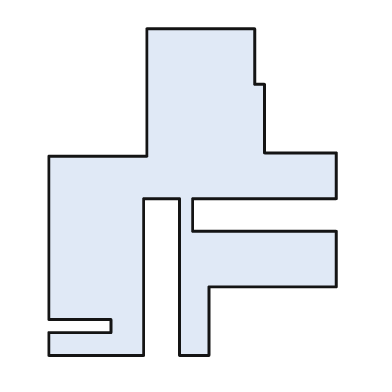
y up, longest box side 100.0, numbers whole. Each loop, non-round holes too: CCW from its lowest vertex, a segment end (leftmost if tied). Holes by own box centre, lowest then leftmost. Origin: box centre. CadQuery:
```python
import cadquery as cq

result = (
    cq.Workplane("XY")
    .moveTo(-44.0, -50.0)
    .lineTo(-15.0, -50.0)
    .lineTo(-15.0, -2.0)
    .lineTo(-4.0, -2.0)
    .lineTo(-4.0, -50.0)
    .lineTo(5.0, -50.0)
    .lineTo(5.0, -29.0)
    .lineTo(44.0, -29.0)
    .lineTo(44.0, -12.0)
    .lineTo(0.0, -12.0)
    .lineTo(0.0, -2.0)
    .lineTo(44.0, -2.0)
    .lineTo(44.0, 12.0)
    .lineTo(22.0, 12.0)
    .lineTo(22.0, 33.0)
    .lineTo(19.0, 33.0)
    .lineTo(19.0, 50.0)
    .lineTo(-14.0, 50.0)
    .lineTo(-14.0, 11.0)
    .lineTo(-44.0, 11.0)
    .lineTo(-44.0, -39.0)
    .lineTo(-25.0, -39.0)
    .lineTo(-25.0, -43.0)
    .lineTo(-44.0, -43.0)
    .close()
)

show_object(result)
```